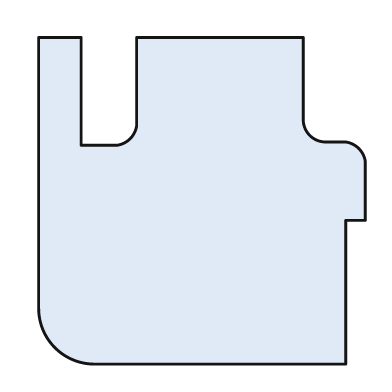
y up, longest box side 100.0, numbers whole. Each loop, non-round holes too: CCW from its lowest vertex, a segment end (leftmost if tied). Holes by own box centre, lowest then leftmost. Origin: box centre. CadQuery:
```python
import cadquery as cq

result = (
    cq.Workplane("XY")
    .moveTo(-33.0, -50.0)
    .lineTo(44.0, -50.0)
    .lineTo(44.0, -6.0)
    .lineTo(50.0, -6.0)
    .lineTo(50.0, 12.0)
    .threePointArc((48.0, 16.0), (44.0, 18.0))
    .lineTo(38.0, 18.0)
    .threePointArc((33.0, 20.0), (31.0, 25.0))
    .lineTo(31.0, 50.0)
    .lineTo(-20.0, 50.0)
    .lineTo(-20.0, 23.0)
    .threePointArc((-22.0, 19.0), (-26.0, 17.0))
    .lineTo(-37.0, 17.0)
    .lineTo(-37.0, 50.0)
    .lineTo(-50.0, 50.0)
    .lineTo(-50.0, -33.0)
    .threePointArc((-45.0, -45.0), (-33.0, -50.0))
    .close()
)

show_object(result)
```